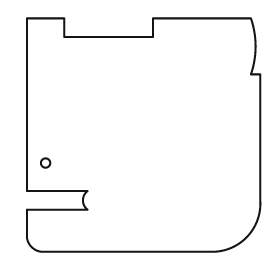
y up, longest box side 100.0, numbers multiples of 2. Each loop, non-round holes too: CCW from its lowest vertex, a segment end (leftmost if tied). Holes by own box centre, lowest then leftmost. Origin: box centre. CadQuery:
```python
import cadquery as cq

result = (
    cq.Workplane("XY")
    .moveTo(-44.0, -50.0)
    .lineTo(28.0, -50.0)
    .threePointArc((44.0, -44.0), (50.0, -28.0))
    .lineTo(50.0, 26.0)
    .lineTo(46.0, 26.0)
    .threePointArc((48.0, 38.0), (46.0, 50.0))
    .lineTo(4.0, 50.0)
    .lineTo(4.0, 42.0)
    .lineTo(-34.0, 42.0)
    .lineTo(-34.0, 50.0)
    .lineTo(-50.0, 50.0)
    .lineTo(-50.0, -24.0)
    .lineTo(-24.0, -24.0)
    .threePointArc((-26.0, -28.0), (-24.0, -32.0))
    .lineTo(-50.0, -32.0)
    .lineTo(-50.0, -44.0)
    .threePointArc((-48.0, -48.0), (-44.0, -50.0))
    .close()
    .moveTo(-42.0, -12.0)
    .circle(2.0)
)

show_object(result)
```